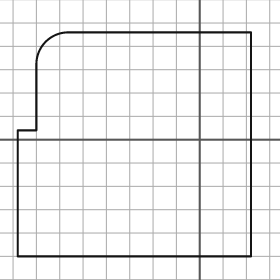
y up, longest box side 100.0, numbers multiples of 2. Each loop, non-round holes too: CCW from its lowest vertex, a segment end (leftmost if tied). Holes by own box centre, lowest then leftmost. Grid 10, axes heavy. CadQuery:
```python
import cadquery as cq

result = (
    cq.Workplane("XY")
    .moveTo(-78.0, -50.0)
    .lineTo(22.0, -50.0)
    .lineTo(22.0, 46.0)
    .lineTo(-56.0, 46.0)
    .threePointArc((-66.0, 42.0), (-70.0, 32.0))
    .lineTo(-70.0, 4.0)
    .lineTo(-78.0, 4.0)
    .close()
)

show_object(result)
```